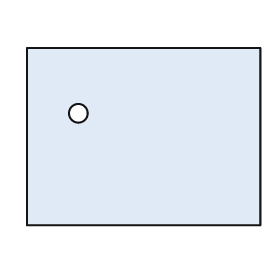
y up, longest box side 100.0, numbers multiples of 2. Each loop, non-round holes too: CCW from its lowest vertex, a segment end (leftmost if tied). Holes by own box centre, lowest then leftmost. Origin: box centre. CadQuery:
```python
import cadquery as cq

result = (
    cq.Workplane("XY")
    .moveTo(-50.0, -38.0)
    .lineTo(50.0, -38.0)
    .lineTo(50.0, 38.0)
    .lineTo(-50.0, 38.0)
    .close()
    .moveTo(-28.0, 10.0)
    .circle(4.0)
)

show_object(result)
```